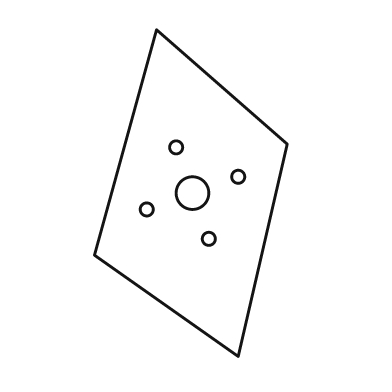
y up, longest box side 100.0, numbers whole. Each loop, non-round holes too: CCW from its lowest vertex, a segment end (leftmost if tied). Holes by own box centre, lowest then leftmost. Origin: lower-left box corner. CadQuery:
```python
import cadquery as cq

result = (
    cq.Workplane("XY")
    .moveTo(44.0, 0.0)
    .lineTo(59.0, 65.0)
    .lineTo(19.0, 100.0)
    .lineTo(0.0, 31.0)
    .close()
    .moveTo(35.0, 36.0)
    .circle(2.0)
    .moveTo(16.0, 45.0)
    .circle(2.0)
    .moveTo(30.0, 50.0)
    .circle(5.0)
    .moveTo(44.0, 55.0)
    .circle(2.0)
    .moveTo(25.0, 64.0)
    .circle(2.0)
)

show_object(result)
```